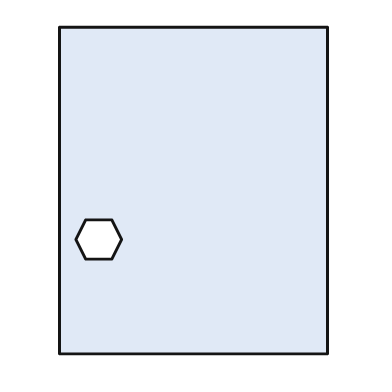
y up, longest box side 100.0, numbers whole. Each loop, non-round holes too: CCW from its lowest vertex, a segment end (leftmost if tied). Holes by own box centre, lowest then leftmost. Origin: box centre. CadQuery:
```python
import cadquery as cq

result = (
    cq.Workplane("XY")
    .moveTo(-41.0, -50.0)
    .lineTo(41.0, -50.0)
    .lineTo(41.0, 50.0)
    .lineTo(-41.0, 50.0)
    .close()
    .moveTo(-33.0, -21.0)
    .lineTo(-25.0, -21.0)
    .lineTo(-22.0, -15.0)
    .lineTo(-25.0, -9.0)
    .lineTo(-33.0, -9.0)
    .lineTo(-36.0, -15.0)
    .close()
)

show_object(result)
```